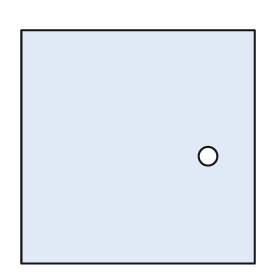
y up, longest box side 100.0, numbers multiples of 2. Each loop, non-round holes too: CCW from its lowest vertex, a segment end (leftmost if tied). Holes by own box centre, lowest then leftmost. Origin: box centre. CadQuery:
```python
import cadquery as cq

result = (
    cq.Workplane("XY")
    .moveTo(-50.0, -50.0)
    .lineTo(50.0, -50.0)
    .lineTo(50.0, 50.0)
    .lineTo(-50.0, 50.0)
    .close()
    .moveTo(30.0, -4.0)
    .circle(4.0)
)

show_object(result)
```